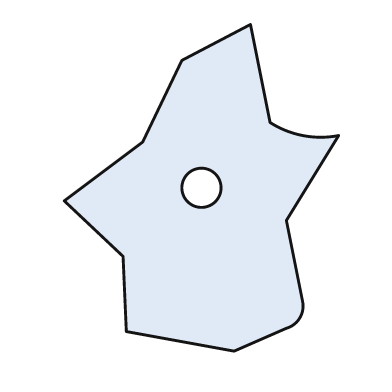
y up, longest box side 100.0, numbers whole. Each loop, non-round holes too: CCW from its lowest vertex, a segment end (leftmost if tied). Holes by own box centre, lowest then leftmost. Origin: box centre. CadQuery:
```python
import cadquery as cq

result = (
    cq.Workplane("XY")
    .moveTo(10.0, -50.0)
    .lineTo(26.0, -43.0)
    .threePointArc((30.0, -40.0), (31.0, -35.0))
    .lineTo(26.0, -10.0)
    .lineTo(42.0, 16.0)
    .threePointArc((31.0, 16.0), (21.0, 20.0))
    .lineTo(15.0, 50.0)
    .lineTo(-6.0, 39.0)
    .lineTo(-18.0, 14.0)
    .lineTo(-42.0, -4.0)
    .lineTo(-24.0, -21.0)
    .lineTo(-23.0, -44.0)
    .close()
    .moveTo(0.0, 0.0)
    .circle(6.0)
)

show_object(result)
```